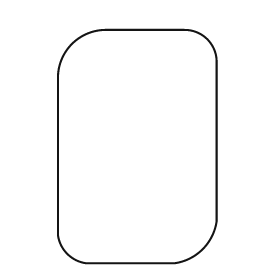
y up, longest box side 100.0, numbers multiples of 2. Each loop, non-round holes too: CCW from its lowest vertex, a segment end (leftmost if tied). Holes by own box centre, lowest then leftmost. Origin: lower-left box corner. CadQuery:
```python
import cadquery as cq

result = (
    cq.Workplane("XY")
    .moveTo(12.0, 0.0)
    .lineTo(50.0, 0.0)
    .threePointArc((62.0, 6.0), (68.0, 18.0))
    .lineTo(68.0, 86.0)
    .threePointArc((64.0, 96.0), (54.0, 100.0))
    .lineTo(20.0, 100.0)
    .threePointArc((6.0, 94.0), (0.0, 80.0))
    .lineTo(0.0, 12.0)
    .threePointArc((4.0, 4.0), (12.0, 0.0))
    .close()
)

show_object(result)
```